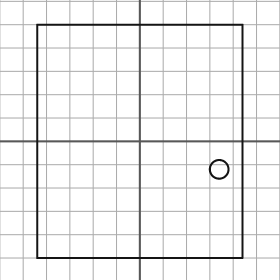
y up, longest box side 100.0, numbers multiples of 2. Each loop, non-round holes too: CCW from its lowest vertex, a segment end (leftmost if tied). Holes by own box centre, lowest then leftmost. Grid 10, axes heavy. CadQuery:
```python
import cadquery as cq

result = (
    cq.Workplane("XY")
    .moveTo(-44.0, -50.0)
    .lineTo(44.0, -50.0)
    .lineTo(44.0, 50.0)
    .lineTo(-44.0, 50.0)
    .close()
    .moveTo(34.0, -12.0)
    .circle(4.0)
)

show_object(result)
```